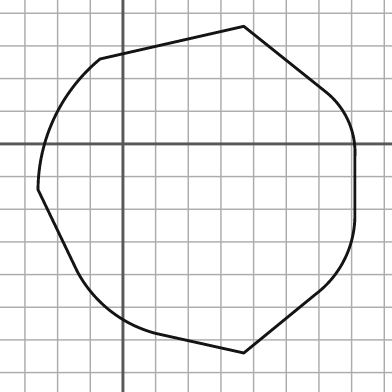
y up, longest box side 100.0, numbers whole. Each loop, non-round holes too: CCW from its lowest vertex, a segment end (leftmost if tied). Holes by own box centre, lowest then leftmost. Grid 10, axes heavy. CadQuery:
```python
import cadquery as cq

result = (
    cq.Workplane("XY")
    .moveTo(37.0, -64.0)
    .lineTo(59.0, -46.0)
    .threePointArc((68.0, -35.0), (71.0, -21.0))
    .lineTo(71.0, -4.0)
    .threePointArc((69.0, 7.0), (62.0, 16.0))
    .lineTo(37.0, 36.0)
    .lineTo(-7.0, 26.0)
    .threePointArc((-21.0, 8.0), (-26.0, -14.0))
    .lineTo(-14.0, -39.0)
    .threePointArc((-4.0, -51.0), (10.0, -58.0))
    .close()
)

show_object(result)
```